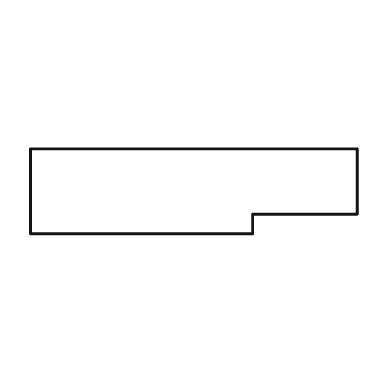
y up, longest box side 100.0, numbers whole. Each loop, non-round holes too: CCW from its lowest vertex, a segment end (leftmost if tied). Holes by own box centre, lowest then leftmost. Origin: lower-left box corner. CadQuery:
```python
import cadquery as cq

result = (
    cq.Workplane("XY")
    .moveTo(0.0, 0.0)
    .lineTo(68.0, 0.0)
    .lineTo(68.0, 6.0)
    .lineTo(100.0, 6.0)
    .lineTo(100.0, 26.0)
    .lineTo(0.0, 26.0)
    .close()
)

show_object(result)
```